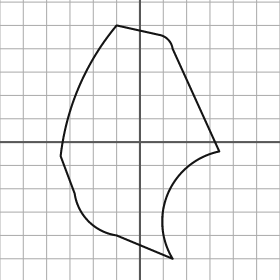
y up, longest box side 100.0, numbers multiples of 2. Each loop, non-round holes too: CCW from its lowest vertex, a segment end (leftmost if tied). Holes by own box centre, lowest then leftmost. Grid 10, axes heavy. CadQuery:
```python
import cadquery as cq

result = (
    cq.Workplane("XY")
    .moveTo(14.0, -50.0)
    .threePointArc((12.0, -22.0), (34.0, -4.0))
    .lineTo(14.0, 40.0)
    .threePointArc((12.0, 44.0), (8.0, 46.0))
    .lineTo(-10.0, 50.0)
    .threePointArc((-26.0, 24.0), (-34.0, -6.0))
    .lineTo(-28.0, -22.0)
    .threePointArc((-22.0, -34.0), (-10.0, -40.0))
    .close()
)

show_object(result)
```